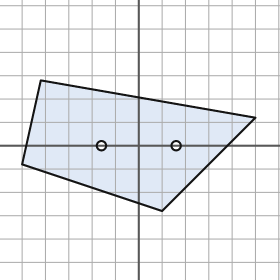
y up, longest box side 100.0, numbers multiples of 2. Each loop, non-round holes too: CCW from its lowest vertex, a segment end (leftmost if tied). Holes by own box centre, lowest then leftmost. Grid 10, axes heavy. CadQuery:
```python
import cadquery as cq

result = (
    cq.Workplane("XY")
    .moveTo(10.0, -28.0)
    .lineTo(50.0, 12.0)
    .lineTo(-42.0, 28.0)
    .lineTo(-50.0, -8.0)
    .close()
    .moveTo(-16.0, 0.0)
    .circle(2.0)
    .moveTo(16.0, 0.0)
    .circle(2.0)
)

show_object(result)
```